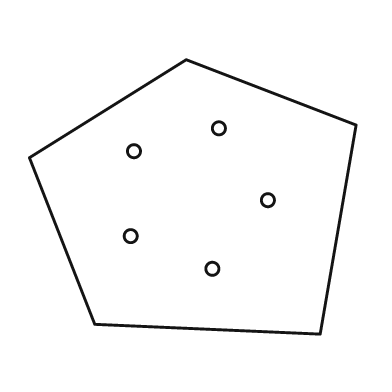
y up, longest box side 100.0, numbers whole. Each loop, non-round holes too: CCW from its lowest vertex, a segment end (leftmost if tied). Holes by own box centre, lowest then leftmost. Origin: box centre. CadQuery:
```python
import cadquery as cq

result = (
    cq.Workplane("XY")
    .moveTo(39.0, -42.0)
    .lineTo(50.0, 22.0)
    .lineTo(-2.0, 42.0)
    .lineTo(-50.0, 12.0)
    .lineTo(-30.0, -39.0)
    .close()
    .moveTo(6.0, -22.0)
    .circle(2.0)
    .moveTo(-19.0, -12.0)
    .circle(2.0)
    .moveTo(23.0, -1.0)
    .circle(2.0)
    .moveTo(-18.0, 14.0)
    .circle(2.0)
    .moveTo(8.0, 21.0)
    .circle(2.0)
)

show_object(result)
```